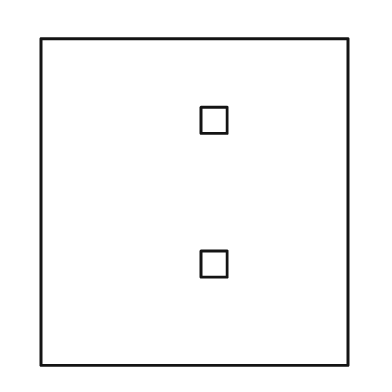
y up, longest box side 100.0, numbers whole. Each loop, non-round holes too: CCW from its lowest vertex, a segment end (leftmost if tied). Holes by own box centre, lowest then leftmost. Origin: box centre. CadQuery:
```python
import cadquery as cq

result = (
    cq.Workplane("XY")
    .moveTo(-47.0, -50.0)
    .lineTo(47.0, -50.0)
    .lineTo(47.0, 50.0)
    .lineTo(-47.0, 50.0)
    .close()
    .moveTo(2.0, -23.0)
    .lineTo(10.0, -23.0)
    .lineTo(10.0, -15.0)
    .lineTo(2.0, -15.0)
    .close()
    .moveTo(2.0, 21.0)
    .lineTo(10.0, 21.0)
    .lineTo(10.0, 29.0)
    .lineTo(2.0, 29.0)
    .close()
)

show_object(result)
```